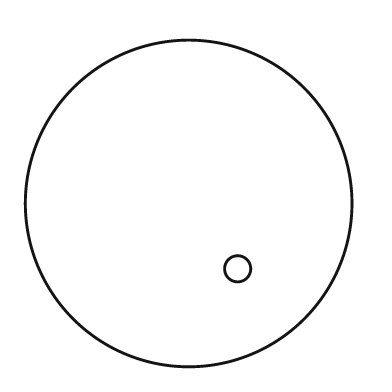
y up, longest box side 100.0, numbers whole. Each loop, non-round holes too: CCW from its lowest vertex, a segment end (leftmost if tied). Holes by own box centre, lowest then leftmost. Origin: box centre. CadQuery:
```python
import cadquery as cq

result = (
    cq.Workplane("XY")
    .moveTo(0.0, 0.0)
    .circle(50.0)
    .moveTo(15.0, -20.0)
    .circle(4.0)
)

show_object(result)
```